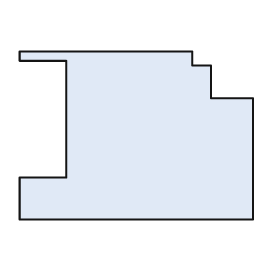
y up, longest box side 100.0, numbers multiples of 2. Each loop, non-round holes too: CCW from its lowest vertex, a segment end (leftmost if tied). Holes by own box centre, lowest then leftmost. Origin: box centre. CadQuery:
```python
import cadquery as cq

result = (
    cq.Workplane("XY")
    .moveTo(-50.0, -36.0)
    .lineTo(50.0, -36.0)
    .lineTo(50.0, 16.0)
    .lineTo(32.0, 16.0)
    .lineTo(32.0, 30.0)
    .lineTo(24.0, 30.0)
    .lineTo(24.0, 36.0)
    .lineTo(-50.0, 36.0)
    .lineTo(-50.0, 32.0)
    .lineTo(-30.0, 32.0)
    .lineTo(-30.0, -18.0)
    .lineTo(-50.0, -18.0)
    .close()
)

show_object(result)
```